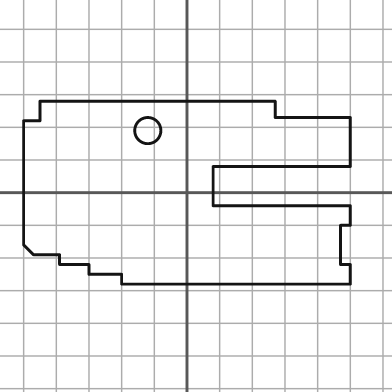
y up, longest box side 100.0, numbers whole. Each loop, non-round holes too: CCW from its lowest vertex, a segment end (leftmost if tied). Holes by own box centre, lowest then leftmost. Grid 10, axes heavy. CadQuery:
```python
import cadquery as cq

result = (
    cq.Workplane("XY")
    .moveTo(-20.0, -28.0)
    .lineTo(50.0, -28.0)
    .lineTo(50.0, -22.0)
    .lineTo(47.0, -22.0)
    .lineTo(47.0, -10.0)
    .lineTo(50.0, -10.0)
    .lineTo(50.0, -4.0)
    .lineTo(8.0, -4.0)
    .lineTo(8.0, 8.0)
    .lineTo(50.0, 8.0)
    .lineTo(50.0, 23.0)
    .lineTo(27.0, 23.0)
    .lineTo(27.0, 28.0)
    .lineTo(-45.0, 28.0)
    .lineTo(-45.0, 22.0)
    .lineTo(-50.0, 22.0)
    .lineTo(-50.0, -16.0)
    .lineTo(-47.0, -19.0)
    .lineTo(-39.0, -19.0)
    .lineTo(-39.0, -22.0)
    .lineTo(-30.0, -22.0)
    .lineTo(-30.0, -25.0)
    .lineTo(-20.0, -25.0)
    .close()
    .moveTo(-12.0, 19.0)
    .circle(4.0)
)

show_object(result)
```